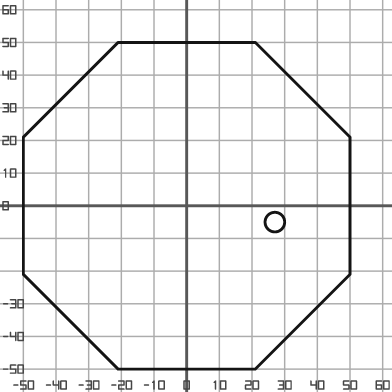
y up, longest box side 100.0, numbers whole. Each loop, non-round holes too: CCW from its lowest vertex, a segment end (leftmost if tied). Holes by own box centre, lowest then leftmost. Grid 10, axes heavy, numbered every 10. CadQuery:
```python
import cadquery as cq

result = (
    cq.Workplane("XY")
    .moveTo(-21.0, -50.0)
    .lineTo(21.0, -50.0)
    .lineTo(50.0, -21.0)
    .lineTo(50.0, 21.0)
    .lineTo(21.0, 50.0)
    .lineTo(-21.0, 50.0)
    .lineTo(-50.0, 21.0)
    .lineTo(-50.0, -21.0)
    .close()
    .moveTo(27.0, -5.0)
    .circle(3.0)
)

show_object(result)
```